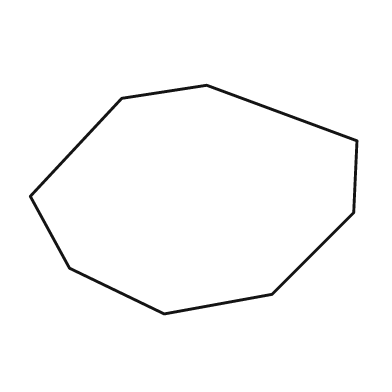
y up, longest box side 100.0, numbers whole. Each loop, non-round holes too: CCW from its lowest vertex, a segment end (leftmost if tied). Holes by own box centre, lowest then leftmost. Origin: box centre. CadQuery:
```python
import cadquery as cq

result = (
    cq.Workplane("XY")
    .moveTo(-9.0, -35.0)
    .lineTo(24.0, -29.0)
    .lineTo(49.0, -4.0)
    .lineTo(50.0, 18.0)
    .lineTo(4.0, 35.0)
    .lineTo(-22.0, 31.0)
    .lineTo(-50.0, 1.0)
    .lineTo(-38.0, -21.0)
    .close()
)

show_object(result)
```